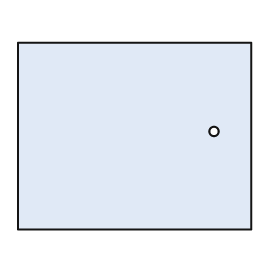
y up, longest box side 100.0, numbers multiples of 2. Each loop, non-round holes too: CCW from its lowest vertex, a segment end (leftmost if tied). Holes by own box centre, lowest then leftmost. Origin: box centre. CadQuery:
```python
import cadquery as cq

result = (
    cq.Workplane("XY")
    .moveTo(-50.0, -40.0)
    .lineTo(50.0, -40.0)
    .lineTo(50.0, 40.0)
    .lineTo(-50.0, 40.0)
    .close()
    .moveTo(34.0, 2.0)
    .circle(2.0)
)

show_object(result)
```